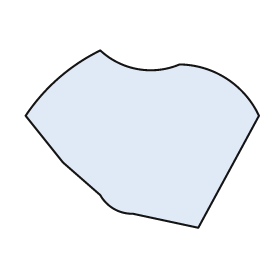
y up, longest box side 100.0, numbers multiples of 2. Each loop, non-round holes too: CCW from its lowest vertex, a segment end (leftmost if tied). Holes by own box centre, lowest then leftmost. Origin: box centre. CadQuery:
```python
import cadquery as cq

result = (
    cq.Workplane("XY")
    .moveTo(24.0, -38.0)
    .lineTo(50.0, 10.0)
    .threePointArc((36.0, 26.0), (16.0, 32.0))
    .threePointArc((-2.0, 30.0), (-18.0, 38.0))
    .threePointArc((-36.0, 26.0), (-50.0, 10.0))
    .lineTo(-34.0, -10.0)
    .lineTo(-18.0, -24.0)
    .threePointArc((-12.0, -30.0), (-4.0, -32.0))
    .close()
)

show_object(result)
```